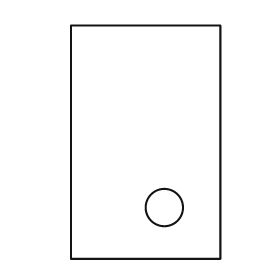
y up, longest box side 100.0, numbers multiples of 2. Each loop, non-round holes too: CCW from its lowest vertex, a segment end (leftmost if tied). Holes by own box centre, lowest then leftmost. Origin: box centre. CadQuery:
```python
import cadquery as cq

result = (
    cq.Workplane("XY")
    .moveTo(-32.0, -50.0)
    .lineTo(32.0, -50.0)
    .lineTo(32.0, 50.0)
    .lineTo(-32.0, 50.0)
    .close()
    .moveTo(8.0, -28.0)
    .circle(8.0)
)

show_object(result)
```